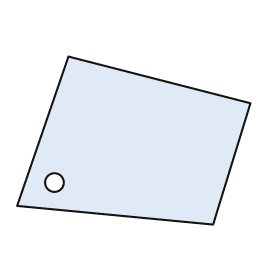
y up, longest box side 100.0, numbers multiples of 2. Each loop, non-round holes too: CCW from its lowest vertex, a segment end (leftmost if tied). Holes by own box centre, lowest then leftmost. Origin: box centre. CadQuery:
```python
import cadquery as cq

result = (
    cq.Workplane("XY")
    .moveTo(34.0, -36.0)
    .lineTo(50.0, 16.0)
    .lineTo(-28.0, 36.0)
    .lineTo(-50.0, -28.0)
    .close()
    .moveTo(-34.0, -18.0)
    .circle(4.0)
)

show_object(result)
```